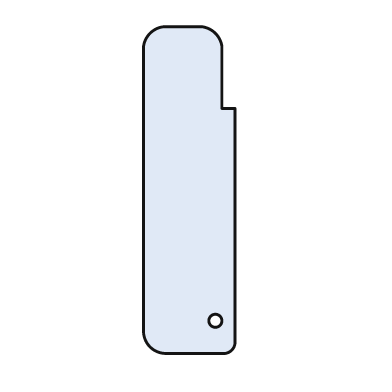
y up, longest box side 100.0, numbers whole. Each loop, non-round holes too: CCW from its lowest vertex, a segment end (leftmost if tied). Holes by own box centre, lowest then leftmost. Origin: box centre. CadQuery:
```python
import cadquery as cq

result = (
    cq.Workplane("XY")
    .moveTo(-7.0, -50.0)
    .lineTo(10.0, -50.0)
    .threePointArc((13.0, -49.0), (14.0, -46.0))
    .lineTo(14.0, 25.0)
    .lineTo(10.0, 25.0)
    .lineTo(10.0, 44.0)
    .threePointArc((8.0, 48.0), (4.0, 50.0))
    .lineTo(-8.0, 50.0)
    .threePointArc((-12.0, 48.0), (-14.0, 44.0))
    .lineTo(-14.0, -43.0)
    .threePointArc((-12.0, -48.0), (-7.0, -50.0))
    .close()
    .moveTo(8.0, -40.0)
    .circle(2.0)
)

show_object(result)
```